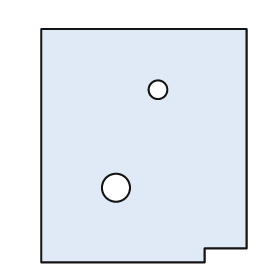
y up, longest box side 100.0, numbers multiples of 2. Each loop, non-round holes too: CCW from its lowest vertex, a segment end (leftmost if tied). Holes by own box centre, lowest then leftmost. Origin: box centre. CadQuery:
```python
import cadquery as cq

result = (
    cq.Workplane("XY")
    .moveTo(-44.0, -50.0)
    .lineTo(26.0, -50.0)
    .lineTo(26.0, -44.0)
    .lineTo(44.0, -44.0)
    .lineTo(44.0, 50.0)
    .lineTo(-44.0, 50.0)
    .close()
    .moveTo(-12.0, -18.0)
    .circle(6.0)
    .moveTo(6.0, 24.0)
    .circle(4.0)
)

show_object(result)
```